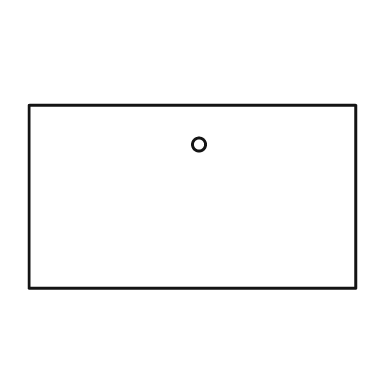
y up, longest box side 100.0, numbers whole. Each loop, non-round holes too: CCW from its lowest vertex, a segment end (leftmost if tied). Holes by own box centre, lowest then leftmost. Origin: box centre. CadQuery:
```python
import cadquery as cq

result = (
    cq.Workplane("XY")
    .moveTo(-50.0, -28.0)
    .lineTo(50.0, -28.0)
    .lineTo(50.0, 28.0)
    .lineTo(-50.0, 28.0)
    .close()
    .moveTo(2.0, 16.0)
    .circle(2.0)
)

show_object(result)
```